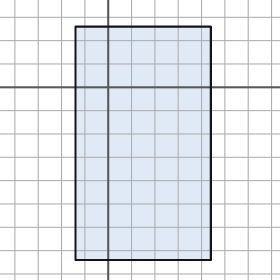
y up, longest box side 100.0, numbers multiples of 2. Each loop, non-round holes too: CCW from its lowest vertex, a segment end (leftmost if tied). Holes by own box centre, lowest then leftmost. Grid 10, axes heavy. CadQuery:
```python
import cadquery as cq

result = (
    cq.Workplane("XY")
    .moveTo(-14.0, -74.0)
    .lineTo(44.0, -74.0)
    .lineTo(44.0, 26.0)
    .lineTo(-14.0, 26.0)
    .close()
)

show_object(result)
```